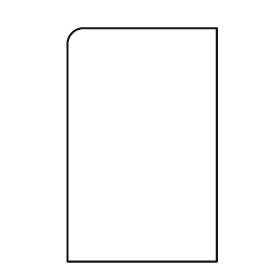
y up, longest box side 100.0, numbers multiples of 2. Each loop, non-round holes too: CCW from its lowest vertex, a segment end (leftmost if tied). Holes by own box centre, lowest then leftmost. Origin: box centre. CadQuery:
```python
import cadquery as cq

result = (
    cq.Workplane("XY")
    .moveTo(-32.0, -50.0)
    .lineTo(32.0, -50.0)
    .lineTo(32.0, 50.0)
    .lineTo(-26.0, 50.0)
    .threePointArc((-30.0, 48.0), (-32.0, 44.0))
    .close()
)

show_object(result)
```